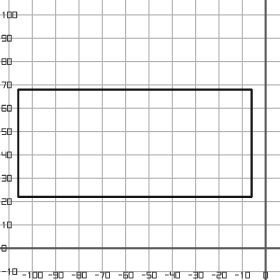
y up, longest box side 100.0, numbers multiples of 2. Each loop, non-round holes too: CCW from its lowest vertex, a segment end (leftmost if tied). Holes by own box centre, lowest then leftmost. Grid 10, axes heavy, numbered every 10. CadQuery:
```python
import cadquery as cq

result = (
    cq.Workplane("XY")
    .moveTo(-106.0, 22.0)
    .lineTo(-6.0, 22.0)
    .lineTo(-6.0, 68.0)
    .lineTo(-106.0, 68.0)
    .close()
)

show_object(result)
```